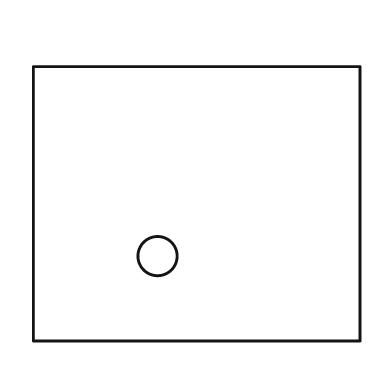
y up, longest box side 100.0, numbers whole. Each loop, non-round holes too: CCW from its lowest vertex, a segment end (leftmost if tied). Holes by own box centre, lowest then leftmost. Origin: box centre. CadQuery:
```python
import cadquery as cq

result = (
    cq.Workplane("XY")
    .moveTo(-50.0, -42.0)
    .lineTo(50.0, -42.0)
    .lineTo(50.0, 42.0)
    .lineTo(-50.0, 42.0)
    .close()
    .moveTo(-12.0, -16.0)
    .circle(6.0)
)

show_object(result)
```